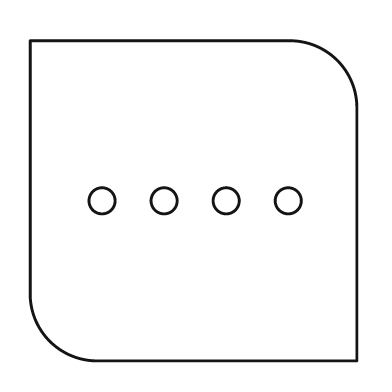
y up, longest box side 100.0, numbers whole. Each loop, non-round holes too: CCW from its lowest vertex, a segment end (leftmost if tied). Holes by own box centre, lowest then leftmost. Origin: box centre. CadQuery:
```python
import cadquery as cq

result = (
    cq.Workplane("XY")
    .moveTo(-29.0, -49.0)
    .lineTo(50.0, -49.0)
    .lineTo(50.0, 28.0)
    .threePointArc((44.0, 43.0), (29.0, 49.0))
    .lineTo(-50.0, 49.0)
    .lineTo(-50.0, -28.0)
    .threePointArc((-44.0, -43.0), (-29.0, -49.0))
    .close()
    .moveTo(-28.0, 0.0)
    .circle(4.0)
    .moveTo(-9.0, 0.0)
    .circle(4.0)
    .moveTo(10.0, 0.0)
    .circle(4.0)
    .moveTo(29.0, 0.0)
    .circle(4.0)
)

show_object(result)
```